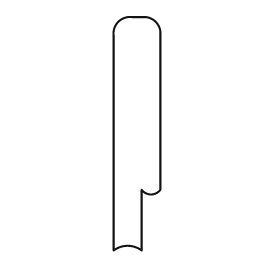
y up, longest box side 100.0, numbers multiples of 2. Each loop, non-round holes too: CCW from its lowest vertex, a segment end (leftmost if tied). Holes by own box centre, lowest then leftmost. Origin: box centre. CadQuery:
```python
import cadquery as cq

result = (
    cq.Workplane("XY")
    .moveTo(-10.0, -50.0)
    .threePointArc((-4.0, -48.0), (2.0, -50.0))
    .lineTo(2.0, -24.0)
    .threePointArc((6.0, -26.0), (10.0, -24.0))
    .lineTo(10.0, 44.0)
    .threePointArc((8.0, 48.0), (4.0, 50.0))
    .lineTo(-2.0, 50.0)
    .threePointArc((-8.0, 48.0), (-10.0, 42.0))
    .close()
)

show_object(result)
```